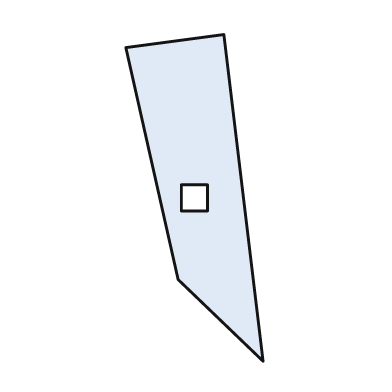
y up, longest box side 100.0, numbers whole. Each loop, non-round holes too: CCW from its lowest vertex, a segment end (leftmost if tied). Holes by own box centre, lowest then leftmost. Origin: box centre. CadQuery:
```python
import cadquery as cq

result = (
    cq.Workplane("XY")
    .moveTo(21.0, -50.0)
    .lineTo(9.0, 50.0)
    .lineTo(-21.0, 46.0)
    .lineTo(-5.0, -25.0)
    .close()
    .moveTo(-4.0, -4.0)
    .lineTo(4.0, -4.0)
    .lineTo(4.0, 4.0)
    .lineTo(-4.0, 4.0)
    .close()
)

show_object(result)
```